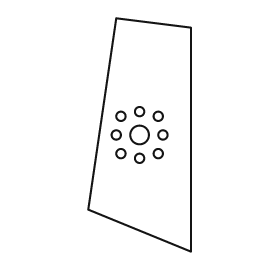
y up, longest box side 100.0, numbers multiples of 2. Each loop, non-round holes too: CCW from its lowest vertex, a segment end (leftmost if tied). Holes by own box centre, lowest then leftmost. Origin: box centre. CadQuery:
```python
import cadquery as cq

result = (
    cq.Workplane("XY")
    .moveTo(22.0, -50.0)
    .lineTo(22.0, 46.0)
    .lineTo(-10.0, 50.0)
    .lineTo(-22.0, -32.0)
    .close()
    .moveTo(0.0, -10.0)
    .circle(2.0)
    .moveTo(-8.0, -8.0)
    .circle(2.0)
    .moveTo(8.0, -8.0)
    .circle(2.0)
    .moveTo(-10.0, 0.0)
    .circle(2.0)
    .moveTo(0.0, 0.0)
    .circle(4.0)
    .moveTo(10.0, 0.0)
    .circle(2.0)
    .moveTo(-8.0, 8.0)
    .circle(2.0)
    .moveTo(8.0, 8.0)
    .circle(2.0)
    .moveTo(0.0, 10.0)
    .circle(2.0)
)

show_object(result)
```